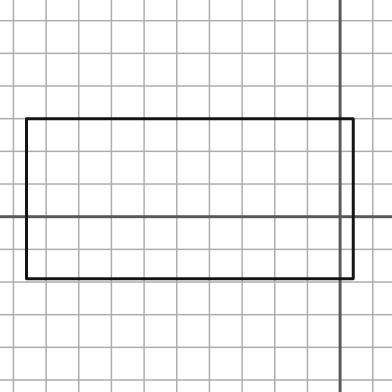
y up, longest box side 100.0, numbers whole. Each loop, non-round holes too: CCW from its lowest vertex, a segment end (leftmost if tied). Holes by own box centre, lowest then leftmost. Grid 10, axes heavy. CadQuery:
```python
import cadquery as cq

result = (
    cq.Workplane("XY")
    .moveTo(-96.0, -19.0)
    .lineTo(4.0, -19.0)
    .lineTo(4.0, 30.0)
    .lineTo(-96.0, 30.0)
    .close()
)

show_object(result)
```